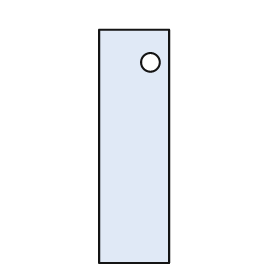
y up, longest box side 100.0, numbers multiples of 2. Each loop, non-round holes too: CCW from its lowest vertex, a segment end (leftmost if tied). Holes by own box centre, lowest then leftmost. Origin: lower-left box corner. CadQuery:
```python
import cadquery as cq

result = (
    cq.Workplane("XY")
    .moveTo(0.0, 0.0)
    .lineTo(30.0, 0.0)
    .lineTo(30.0, 100.0)
    .lineTo(0.0, 100.0)
    .close()
    .moveTo(22.0, 86.0)
    .circle(4.0)
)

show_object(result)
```